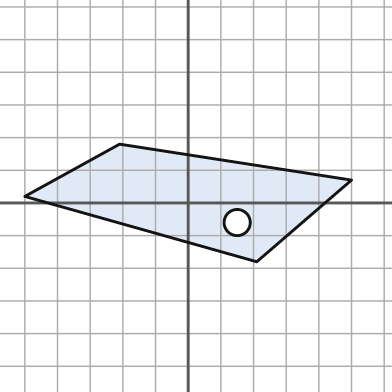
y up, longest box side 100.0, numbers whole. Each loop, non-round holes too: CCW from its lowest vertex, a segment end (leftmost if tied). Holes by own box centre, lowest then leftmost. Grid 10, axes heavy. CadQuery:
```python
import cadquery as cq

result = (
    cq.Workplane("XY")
    .moveTo(21.0, -18.0)
    .lineTo(50.0, 7.0)
    .lineTo(-21.0, 18.0)
    .lineTo(-50.0, 2.0)
    .close()
    .moveTo(15.0, -6.0)
    .circle(4.0)
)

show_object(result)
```